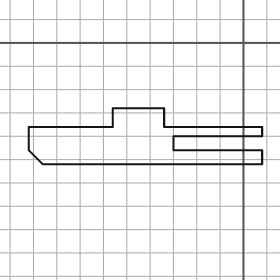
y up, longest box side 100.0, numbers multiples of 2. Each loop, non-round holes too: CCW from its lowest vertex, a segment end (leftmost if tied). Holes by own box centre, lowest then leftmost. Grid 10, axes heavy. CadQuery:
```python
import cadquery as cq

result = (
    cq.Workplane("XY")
    .moveTo(-86.0, -52.0)
    .lineTo(8.0, -52.0)
    .lineTo(8.0, -46.0)
    .lineTo(-30.0, -46.0)
    .lineTo(-30.0, -40.0)
    .lineTo(8.0, -40.0)
    .lineTo(8.0, -36.0)
    .lineTo(-34.0, -36.0)
    .lineTo(-34.0, -28.0)
    .lineTo(-56.0, -28.0)
    .lineTo(-56.0, -36.0)
    .lineTo(-92.0, -36.0)
    .lineTo(-92.0, -46.0)
    .close()
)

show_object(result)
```